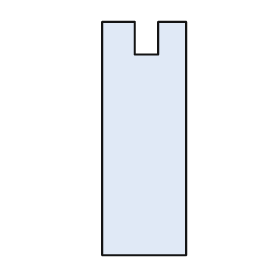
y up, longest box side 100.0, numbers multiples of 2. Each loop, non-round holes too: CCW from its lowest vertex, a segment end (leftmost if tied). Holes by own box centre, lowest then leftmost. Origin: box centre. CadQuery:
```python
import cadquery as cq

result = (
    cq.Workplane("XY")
    .moveTo(-18.0, -50.0)
    .lineTo(18.0, -50.0)
    .lineTo(18.0, 50.0)
    .lineTo(6.0, 50.0)
    .lineTo(6.0, 36.0)
    .lineTo(-4.0, 36.0)
    .lineTo(-4.0, 50.0)
    .lineTo(-18.0, 50.0)
    .close()
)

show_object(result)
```